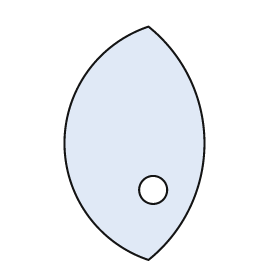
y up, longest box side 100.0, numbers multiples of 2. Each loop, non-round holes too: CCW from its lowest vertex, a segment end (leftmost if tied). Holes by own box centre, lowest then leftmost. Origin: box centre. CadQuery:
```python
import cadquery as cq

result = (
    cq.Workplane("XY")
    .moveTo(6.0, -50.0)
    .threePointArc((30.0, 0.0), (6.0, 50.0))
    .threePointArc((-30.0, 0.0), (6.0, -50.0))
    .close()
    .moveTo(8.0, -20.0)
    .circle(6.0)
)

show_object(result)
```